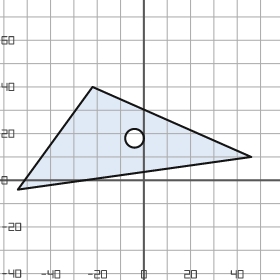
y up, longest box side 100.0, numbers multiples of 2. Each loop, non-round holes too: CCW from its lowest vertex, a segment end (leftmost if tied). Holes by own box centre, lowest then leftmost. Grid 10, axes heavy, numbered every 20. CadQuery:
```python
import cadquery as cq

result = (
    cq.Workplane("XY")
    .moveTo(-54.0, -4.0)
    .lineTo(46.0, 10.0)
    .lineTo(-22.0, 40.0)
    .close()
    .moveTo(-4.0, 18.0)
    .circle(4.0)
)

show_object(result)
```